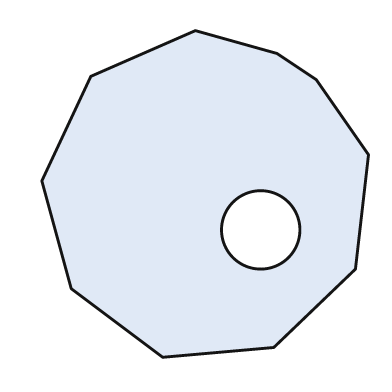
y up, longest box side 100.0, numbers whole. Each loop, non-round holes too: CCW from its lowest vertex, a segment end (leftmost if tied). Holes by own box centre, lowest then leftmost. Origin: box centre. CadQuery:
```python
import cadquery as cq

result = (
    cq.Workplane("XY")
    .moveTo(-13.0, -50.0)
    .lineTo(21.0, -47.0)
    .lineTo(46.0, -23.0)
    .lineTo(50.0, 12.0)
    .lineTo(34.0, 35.0)
    .lineTo(22.0, 43.0)
    .lineTo(-3.0, 50.0)
    .lineTo(-35.0, 36.0)
    .lineTo(-50.0, 4.0)
    .lineTo(-41.0, -29.0)
    .close()
    .moveTo(17.0, -11.0)
    .circle(12.0)
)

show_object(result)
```